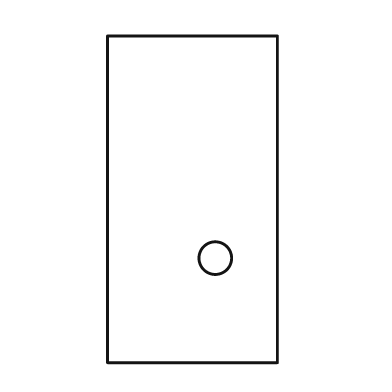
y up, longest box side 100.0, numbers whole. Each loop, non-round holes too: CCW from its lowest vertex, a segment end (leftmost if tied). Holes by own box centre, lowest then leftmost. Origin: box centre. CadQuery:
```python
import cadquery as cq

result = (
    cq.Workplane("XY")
    .moveTo(-26.0, -50.0)
    .lineTo(26.0, -50.0)
    .lineTo(26.0, 50.0)
    .lineTo(-26.0, 50.0)
    .close()
    .moveTo(7.0, -18.0)
    .circle(5.0)
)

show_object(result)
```